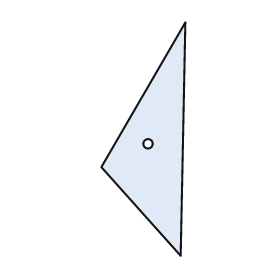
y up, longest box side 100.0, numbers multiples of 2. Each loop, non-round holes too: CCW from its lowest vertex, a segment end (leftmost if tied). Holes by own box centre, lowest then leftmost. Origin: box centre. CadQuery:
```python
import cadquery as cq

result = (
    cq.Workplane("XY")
    .moveTo(16.0, -50.0)
    .lineTo(18.0, 50.0)
    .lineTo(-18.0, -12.0)
    .close()
    .moveTo(2.0, -2.0)
    .circle(2.0)
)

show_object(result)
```